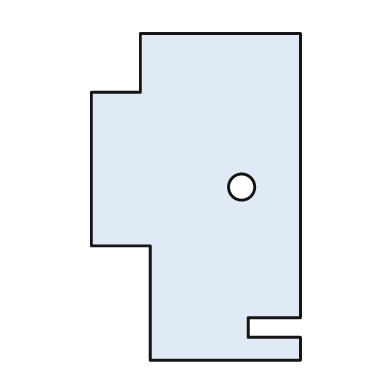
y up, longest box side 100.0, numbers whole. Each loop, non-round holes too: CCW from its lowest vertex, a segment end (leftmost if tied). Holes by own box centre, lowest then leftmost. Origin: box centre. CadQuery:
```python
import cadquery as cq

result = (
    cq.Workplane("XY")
    .moveTo(-14.0, -50.0)
    .lineTo(32.0, -50.0)
    .lineTo(32.0, -43.0)
    .lineTo(16.0, -43.0)
    .lineTo(16.0, -37.0)
    .lineTo(32.0, -37.0)
    .lineTo(32.0, 50.0)
    .lineTo(-17.0, 50.0)
    .lineTo(-17.0, 32.0)
    .lineTo(-32.0, 32.0)
    .lineTo(-32.0, -15.0)
    .lineTo(-14.0, -15.0)
    .close()
    .moveTo(14.0, 3.0)
    .circle(4.0)
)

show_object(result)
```